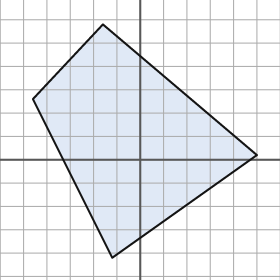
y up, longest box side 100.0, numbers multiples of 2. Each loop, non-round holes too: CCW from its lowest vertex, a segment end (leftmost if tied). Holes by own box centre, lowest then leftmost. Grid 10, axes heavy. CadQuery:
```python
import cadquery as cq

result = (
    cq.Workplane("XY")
    .moveTo(-12.0, -42.0)
    .lineTo(50.0, 2.0)
    .lineTo(-16.0, 58.0)
    .lineTo(-46.0, 26.0)
    .close()
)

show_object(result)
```